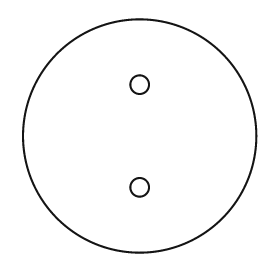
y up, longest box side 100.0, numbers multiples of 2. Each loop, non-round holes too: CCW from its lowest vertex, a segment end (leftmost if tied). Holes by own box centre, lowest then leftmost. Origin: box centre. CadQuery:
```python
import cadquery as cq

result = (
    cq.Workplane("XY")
    .moveTo(0.0, 0.0)
    .circle(50.0)
    .moveTo(0.0, -22.0)
    .circle(4.0)
    .moveTo(0.0, 22.0)
    .circle(4.0)
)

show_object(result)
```